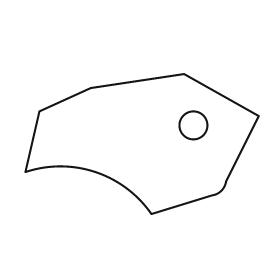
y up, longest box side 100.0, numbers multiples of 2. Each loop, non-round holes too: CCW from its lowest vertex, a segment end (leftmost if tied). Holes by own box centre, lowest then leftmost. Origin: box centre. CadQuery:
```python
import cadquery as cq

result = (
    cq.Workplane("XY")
    .moveTo(4.0, -30.0)
    .lineTo(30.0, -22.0)
    .threePointArc((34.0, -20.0), (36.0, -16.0))
    .lineTo(50.0, 12.0)
    .lineTo(18.0, 30.0)
    .lineTo(-22.0, 24.0)
    .lineTo(-44.0, 14.0)
    .lineTo(-50.0, -12.0)
    .threePointArc((-20.0, -12.0), (4.0, -30.0))
    .close()
    .moveTo(22.0, 8.0)
    .circle(6.0)
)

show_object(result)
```